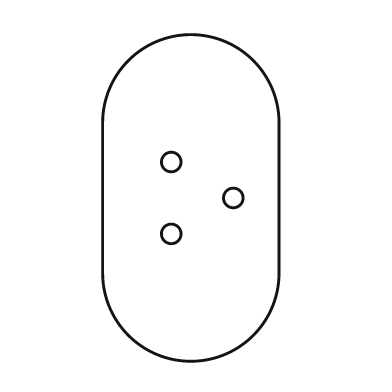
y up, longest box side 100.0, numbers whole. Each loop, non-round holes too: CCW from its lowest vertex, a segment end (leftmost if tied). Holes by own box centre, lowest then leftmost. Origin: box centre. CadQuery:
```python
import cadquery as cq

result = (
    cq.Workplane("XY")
    .moveTo(-27.0, -23.0)
    .threePointArc((0.0, -50.0), (27.0, -23.0))
    .lineTo(27.0, 23.0)
    .threePointArc((0.0, 50.0), (-27.0, 23.0))
    .close()
    .moveTo(-6.0, -11.0)
    .circle(3.0)
    .moveTo(13.0, 0.0)
    .circle(3.0)
    .moveTo(-6.0, 11.0)
    .circle(3.0)
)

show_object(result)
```